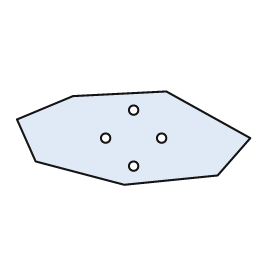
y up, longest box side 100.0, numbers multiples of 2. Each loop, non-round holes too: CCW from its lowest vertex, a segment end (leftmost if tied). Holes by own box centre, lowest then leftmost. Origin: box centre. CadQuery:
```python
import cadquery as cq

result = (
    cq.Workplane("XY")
    .moveTo(-4.0, -20.0)
    .lineTo(36.0, -16.0)
    .lineTo(50.0, 0.0)
    .lineTo(14.0, 20.0)
    .lineTo(-26.0, 18.0)
    .lineTo(-50.0, 8.0)
    .lineTo(-42.0, -10.0)
    .close()
    .moveTo(0.0, -12.0)
    .circle(2.0)
    .moveTo(-12.0, 0.0)
    .circle(2.0)
    .moveTo(12.0, 0.0)
    .circle(2.0)
    .moveTo(0.0, 12.0)
    .circle(2.0)
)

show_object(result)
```